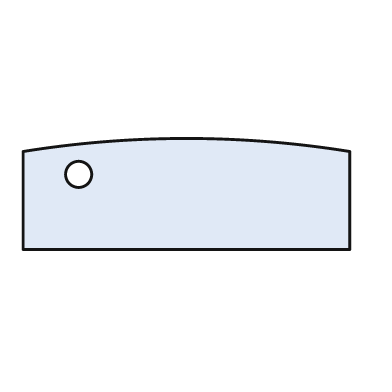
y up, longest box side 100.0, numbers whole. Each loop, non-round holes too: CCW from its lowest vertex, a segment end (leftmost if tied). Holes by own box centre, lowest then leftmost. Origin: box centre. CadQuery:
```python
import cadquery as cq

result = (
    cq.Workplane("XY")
    .moveTo(-50.0, -17.0)
    .lineTo(50.0, -17.0)
    .lineTo(50.0, 13.0)
    .threePointArc((0.0, 17.0), (-50.0, 13.0))
    .close()
    .moveTo(-33.0, 6.0)
    .circle(4.0)
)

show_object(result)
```